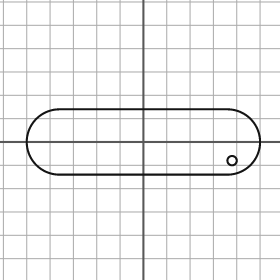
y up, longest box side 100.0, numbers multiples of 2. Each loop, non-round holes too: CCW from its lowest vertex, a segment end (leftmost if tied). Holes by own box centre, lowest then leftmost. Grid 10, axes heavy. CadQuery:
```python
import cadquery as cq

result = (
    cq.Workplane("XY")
    .moveTo(-36.0, -14.0)
    .lineTo(36.0, -14.0)
    .threePointArc((50.0, 0.0), (36.0, 14.0))
    .lineTo(-36.0, 14.0)
    .threePointArc((-50.0, 0.0), (-36.0, -14.0))
    .close()
    .moveTo(38.0, -8.0)
    .circle(2.0)
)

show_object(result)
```